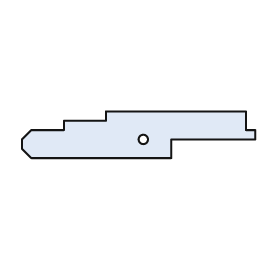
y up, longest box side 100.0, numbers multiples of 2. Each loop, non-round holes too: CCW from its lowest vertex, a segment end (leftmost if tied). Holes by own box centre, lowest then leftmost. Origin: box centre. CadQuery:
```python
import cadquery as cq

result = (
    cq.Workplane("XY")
    .moveTo(-46.0, -10.0)
    .lineTo(14.0, -10.0)
    .lineTo(14.0, -2.0)
    .lineTo(50.0, -2.0)
    .lineTo(50.0, 2.0)
    .lineTo(46.0, 2.0)
    .lineTo(46.0, 10.0)
    .lineTo(-14.0, 10.0)
    .lineTo(-14.0, 6.0)
    .lineTo(-32.0, 6.0)
    .lineTo(-32.0, 2.0)
    .lineTo(-46.0, 2.0)
    .lineTo(-50.0, -2.0)
    .lineTo(-50.0, -6.0)
    .close()
    .moveTo(2.0, -2.0)
    .circle(2.0)
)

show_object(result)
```